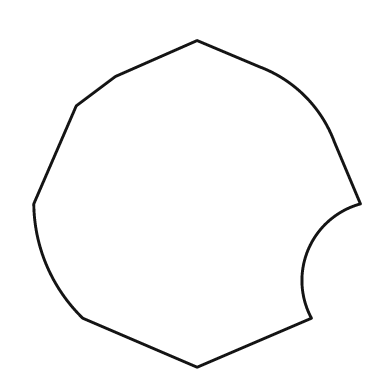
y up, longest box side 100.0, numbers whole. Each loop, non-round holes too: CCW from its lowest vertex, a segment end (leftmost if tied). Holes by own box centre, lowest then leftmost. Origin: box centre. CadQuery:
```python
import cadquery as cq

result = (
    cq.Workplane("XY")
    .moveTo(0.0, -50.0)
    .lineTo(35.0, -35.0)
    .threePointArc((34.0, -14.0), (50.0, 0.0))
    .lineTo(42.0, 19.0)
    .threePointArc((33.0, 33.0), (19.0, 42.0))
    .lineTo(0.0, 50.0)
    .lineTo(-25.0, 39.0)
    .lineTo(-37.0, 30.0)
    .lineTo(-50.0, 0.0)
    .threePointArc((-46.0, -19.0), (-35.0, -35.0))
    .close()
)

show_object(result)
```